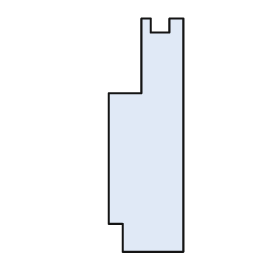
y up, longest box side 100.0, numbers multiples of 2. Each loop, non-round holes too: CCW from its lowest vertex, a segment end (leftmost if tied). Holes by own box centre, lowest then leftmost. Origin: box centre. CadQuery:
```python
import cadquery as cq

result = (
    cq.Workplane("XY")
    .moveTo(-10.0, -50.0)
    .lineTo(16.0, -50.0)
    .lineTo(16.0, 50.0)
    .lineTo(10.0, 50.0)
    .lineTo(10.0, 44.0)
    .lineTo(2.0, 44.0)
    .lineTo(2.0, 50.0)
    .lineTo(-2.0, 50.0)
    .lineTo(-2.0, 18.0)
    .lineTo(-16.0, 18.0)
    .lineTo(-16.0, -38.0)
    .lineTo(-10.0, -38.0)
    .close()
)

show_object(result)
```